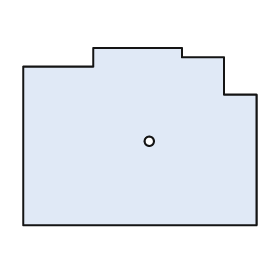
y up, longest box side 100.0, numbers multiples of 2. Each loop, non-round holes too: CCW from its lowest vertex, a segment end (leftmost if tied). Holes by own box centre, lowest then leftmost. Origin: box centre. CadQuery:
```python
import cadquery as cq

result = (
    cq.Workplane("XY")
    .moveTo(-50.0, -38.0)
    .lineTo(50.0, -38.0)
    .lineTo(50.0, 18.0)
    .lineTo(36.0, 18.0)
    .lineTo(36.0, 34.0)
    .lineTo(18.0, 34.0)
    .lineTo(18.0, 38.0)
    .lineTo(-20.0, 38.0)
    .lineTo(-20.0, 30.0)
    .lineTo(-50.0, 30.0)
    .close()
    .moveTo(4.0, -2.0)
    .circle(2.0)
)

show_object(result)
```